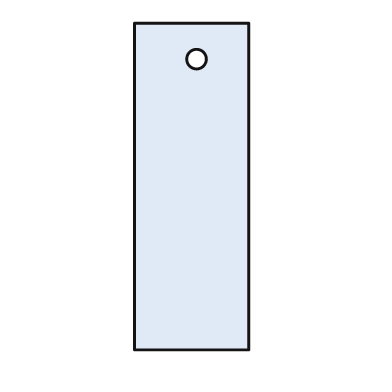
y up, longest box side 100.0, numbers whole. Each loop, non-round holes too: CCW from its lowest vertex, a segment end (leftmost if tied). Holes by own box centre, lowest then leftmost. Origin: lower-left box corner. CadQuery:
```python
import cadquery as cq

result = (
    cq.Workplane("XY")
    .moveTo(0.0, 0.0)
    .lineTo(35.0, 0.0)
    .lineTo(35.0, 100.0)
    .lineTo(0.0, 100.0)
    .close()
    .moveTo(19.0, 89.0)
    .circle(3.0)
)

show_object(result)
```